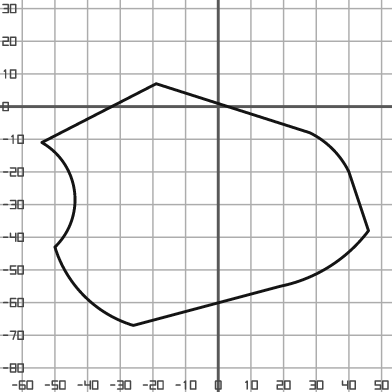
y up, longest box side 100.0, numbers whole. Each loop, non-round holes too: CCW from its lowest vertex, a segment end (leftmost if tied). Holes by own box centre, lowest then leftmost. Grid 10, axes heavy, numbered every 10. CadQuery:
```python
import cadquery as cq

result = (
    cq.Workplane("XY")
    .moveTo(-26.0, -67.0)
    .lineTo(19.0, -55.0)
    .threePointArc((34.0, -49.0), (46.0, -38.0))
    .lineTo(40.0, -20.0)
    .threePointArc((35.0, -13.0), (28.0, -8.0))
    .lineTo(-19.0, 7.0)
    .lineTo(-54.0, -11.0)
    .threePointArc((-44.0, -26.0), (-50.0, -43.0))
    .threePointArc((-41.0, -58.0), (-26.0, -67.0))
    .close()
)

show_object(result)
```